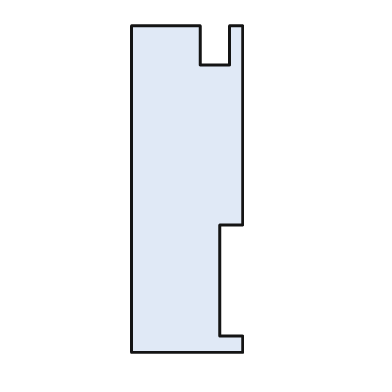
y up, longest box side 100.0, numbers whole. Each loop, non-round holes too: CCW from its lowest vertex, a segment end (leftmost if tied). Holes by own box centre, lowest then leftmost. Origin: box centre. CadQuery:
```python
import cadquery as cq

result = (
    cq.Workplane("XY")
    .moveTo(-17.0, -50.0)
    .lineTo(17.0, -50.0)
    .lineTo(17.0, -45.0)
    .lineTo(10.0, -45.0)
    .lineTo(10.0, -11.0)
    .lineTo(17.0, -11.0)
    .lineTo(17.0, 50.0)
    .lineTo(13.0, 50.0)
    .lineTo(13.0, 38.0)
    .lineTo(4.0, 38.0)
    .lineTo(4.0, 50.0)
    .lineTo(-17.0, 50.0)
    .close()
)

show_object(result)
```